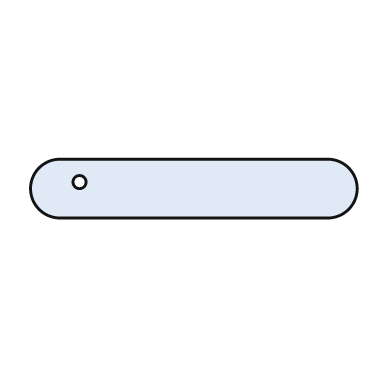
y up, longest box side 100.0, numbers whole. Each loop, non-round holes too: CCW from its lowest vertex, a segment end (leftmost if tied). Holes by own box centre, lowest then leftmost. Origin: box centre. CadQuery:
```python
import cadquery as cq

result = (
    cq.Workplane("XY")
    .moveTo(-41.0, -9.0)
    .lineTo(41.0, -9.0)
    .threePointArc((50.0, 0.0), (41.0, 9.0))
    .lineTo(-41.0, 9.0)
    .threePointArc((-50.0, 0.0), (-41.0, -9.0))
    .close()
    .moveTo(-35.0, 2.0)
    .circle(2.0)
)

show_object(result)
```